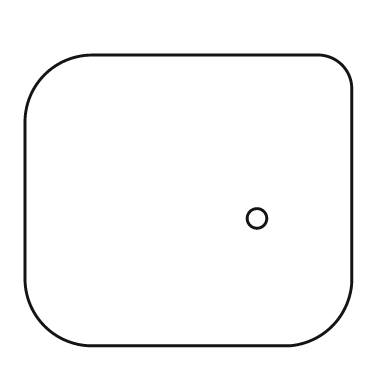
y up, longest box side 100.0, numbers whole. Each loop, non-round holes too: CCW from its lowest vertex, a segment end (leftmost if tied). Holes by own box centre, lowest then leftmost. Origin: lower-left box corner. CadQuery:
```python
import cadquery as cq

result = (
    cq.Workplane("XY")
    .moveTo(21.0, 0.0)
    .lineTo(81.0, 0.0)
    .threePointArc((94.0, 6.0), (100.0, 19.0))
    .lineTo(100.0, 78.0)
    .threePointArc((97.0, 86.0), (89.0, 89.0))
    .lineTo(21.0, 89.0)
    .threePointArc((6.0, 83.0), (0.0, 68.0))
    .lineTo(0.0, 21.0)
    .threePointArc((6.0, 6.0), (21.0, 0.0))
    .close()
    .moveTo(71.0, 39.0)
    .circle(3.0)
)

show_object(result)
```